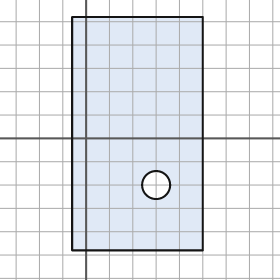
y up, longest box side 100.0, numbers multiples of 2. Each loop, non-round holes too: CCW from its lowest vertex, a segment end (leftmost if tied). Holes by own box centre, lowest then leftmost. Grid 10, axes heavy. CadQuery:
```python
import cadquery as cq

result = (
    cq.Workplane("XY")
    .moveTo(-6.0, -48.0)
    .lineTo(50.0, -48.0)
    .lineTo(50.0, 52.0)
    .lineTo(-6.0, 52.0)
    .close()
    .moveTo(30.0, -20.0)
    .circle(6.0)
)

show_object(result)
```